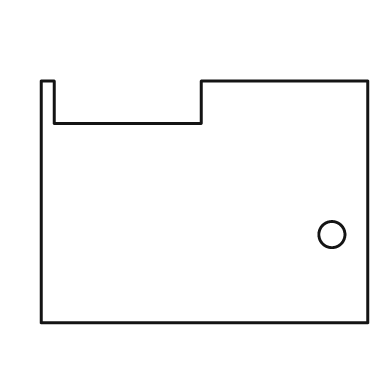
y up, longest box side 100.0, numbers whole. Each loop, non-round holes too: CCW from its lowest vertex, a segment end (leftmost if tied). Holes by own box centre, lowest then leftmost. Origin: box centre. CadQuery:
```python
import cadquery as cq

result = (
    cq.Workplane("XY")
    .moveTo(-50.0, -37.0)
    .lineTo(50.0, -37.0)
    .lineTo(50.0, 37.0)
    .lineTo(-1.0, 37.0)
    .lineTo(-1.0, 24.0)
    .lineTo(-46.0, 24.0)
    .lineTo(-46.0, 37.0)
    .lineTo(-50.0, 37.0)
    .close()
    .moveTo(39.0, -10.0)
    .circle(4.0)
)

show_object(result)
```